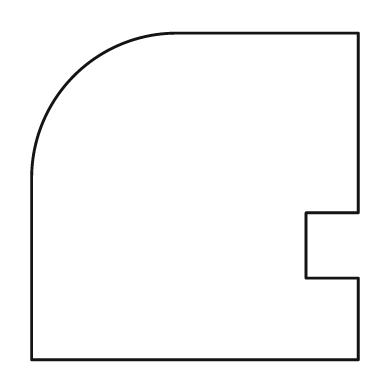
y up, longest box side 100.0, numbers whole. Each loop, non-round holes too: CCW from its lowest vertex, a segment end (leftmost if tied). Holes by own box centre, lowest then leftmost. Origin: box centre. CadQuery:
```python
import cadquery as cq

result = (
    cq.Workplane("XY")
    .moveTo(-50.0, -50.0)
    .lineTo(50.0, -50.0)
    .lineTo(50.0, -25.0)
    .lineTo(34.0, -25.0)
    .lineTo(34.0, -5.0)
    .lineTo(50.0, -5.0)
    .lineTo(50.0, 50.0)
    .lineTo(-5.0, 50.0)
    .threePointArc((-37.0, 37.0), (-50.0, 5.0))
    .close()
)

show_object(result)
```